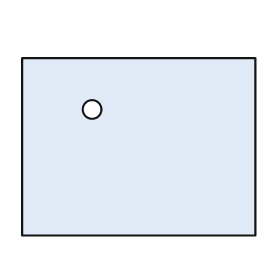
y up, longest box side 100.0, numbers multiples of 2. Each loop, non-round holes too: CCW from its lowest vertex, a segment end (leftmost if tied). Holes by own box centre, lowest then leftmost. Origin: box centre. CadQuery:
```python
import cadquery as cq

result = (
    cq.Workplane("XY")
    .moveTo(-50.0, -38.0)
    .lineTo(50.0, -38.0)
    .lineTo(50.0, 38.0)
    .lineTo(-50.0, 38.0)
    .close()
    .moveTo(-20.0, 16.0)
    .circle(4.0)
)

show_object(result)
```